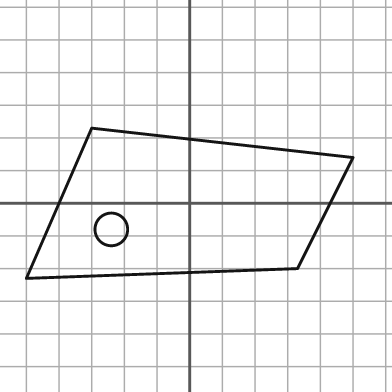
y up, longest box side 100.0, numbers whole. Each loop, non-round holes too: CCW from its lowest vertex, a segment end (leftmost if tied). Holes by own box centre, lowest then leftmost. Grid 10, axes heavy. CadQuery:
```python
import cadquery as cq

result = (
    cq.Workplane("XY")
    .moveTo(-50.0, -23.0)
    .lineTo(33.0, -20.0)
    .lineTo(50.0, 14.0)
    .lineTo(-30.0, 23.0)
    .close()
    .moveTo(-24.0, -8.0)
    .circle(5.0)
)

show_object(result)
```